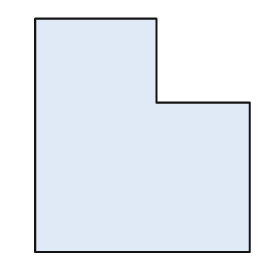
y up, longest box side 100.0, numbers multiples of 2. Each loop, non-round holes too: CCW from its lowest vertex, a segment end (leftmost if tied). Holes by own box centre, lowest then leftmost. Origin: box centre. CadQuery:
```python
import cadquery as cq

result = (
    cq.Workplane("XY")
    .moveTo(-46.0, -50.0)
    .lineTo(46.0, -50.0)
    .lineTo(46.0, 14.0)
    .lineTo(6.0, 14.0)
    .lineTo(6.0, 50.0)
    .lineTo(-46.0, 50.0)
    .close()
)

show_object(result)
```